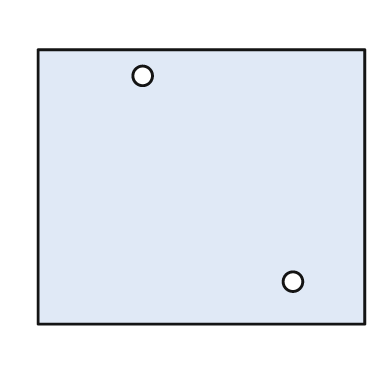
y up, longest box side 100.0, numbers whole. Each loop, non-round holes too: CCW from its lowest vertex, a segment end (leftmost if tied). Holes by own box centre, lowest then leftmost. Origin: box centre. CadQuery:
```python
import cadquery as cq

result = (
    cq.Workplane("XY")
    .moveTo(-50.0, -42.0)
    .lineTo(50.0, -42.0)
    .lineTo(50.0, 42.0)
    .lineTo(-50.0, 42.0)
    .close()
    .moveTo(28.0, -29.0)
    .circle(3.0)
    .moveTo(-18.0, 34.0)
    .circle(3.0)
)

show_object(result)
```